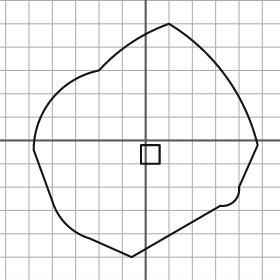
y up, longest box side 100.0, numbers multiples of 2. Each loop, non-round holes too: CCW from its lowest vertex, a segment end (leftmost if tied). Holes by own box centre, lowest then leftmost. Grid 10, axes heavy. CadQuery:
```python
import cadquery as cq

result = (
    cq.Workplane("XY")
    .moveTo(-6.0, -50.0)
    .lineTo(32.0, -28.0)
    .threePointArc((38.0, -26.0), (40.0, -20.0))
    .lineTo(48.0, -2.0)
    .threePointArc((34.0, 28.0), (10.0, 50.0))
    .threePointArc((-6.0, 42.0), (-20.0, 30.0))
    .threePointArc((-40.0, 18.0), (-48.0, -4.0))
    .lineTo(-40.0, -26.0)
    .threePointArc((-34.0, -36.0), (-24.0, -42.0))
    .close()
    .moveTo(-2.0, -10.0)
    .lineTo(6.0, -10.0)
    .lineTo(6.0, -2.0)
    .lineTo(-2.0, -2.0)
    .close()
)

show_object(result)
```